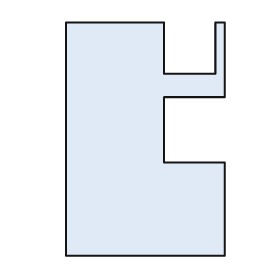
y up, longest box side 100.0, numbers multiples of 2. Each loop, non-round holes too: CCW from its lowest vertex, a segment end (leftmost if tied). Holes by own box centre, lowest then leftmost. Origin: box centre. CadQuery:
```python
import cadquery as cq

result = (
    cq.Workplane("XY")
    .moveTo(-34.0, -50.0)
    .lineTo(34.0, -50.0)
    .lineTo(34.0, -10.0)
    .lineTo(8.0, -10.0)
    .lineTo(8.0, 18.0)
    .lineTo(34.0, 18.0)
    .lineTo(34.0, 50.0)
    .lineTo(30.0, 50.0)
    .lineTo(30.0, 28.0)
    .lineTo(8.0, 28.0)
    .lineTo(8.0, 50.0)
    .lineTo(-34.0, 50.0)
    .close()
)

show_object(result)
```